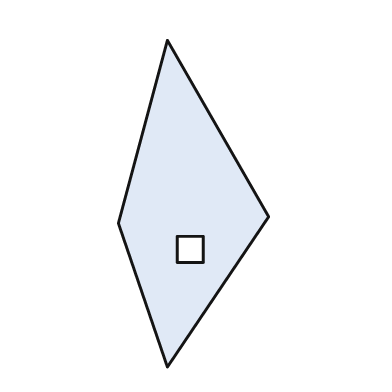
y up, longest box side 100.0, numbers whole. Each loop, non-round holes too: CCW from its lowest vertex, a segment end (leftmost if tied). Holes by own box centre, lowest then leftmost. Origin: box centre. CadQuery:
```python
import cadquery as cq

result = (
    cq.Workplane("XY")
    .moveTo(-8.0, -50.0)
    .lineTo(23.0, -4.0)
    .lineTo(-8.0, 50.0)
    .lineTo(-23.0, -6.0)
    .close()
    .moveTo(-5.0, -18.0)
    .lineTo(3.0, -18.0)
    .lineTo(3.0, -10.0)
    .lineTo(-5.0, -10.0)
    .close()
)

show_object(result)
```